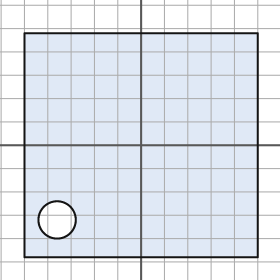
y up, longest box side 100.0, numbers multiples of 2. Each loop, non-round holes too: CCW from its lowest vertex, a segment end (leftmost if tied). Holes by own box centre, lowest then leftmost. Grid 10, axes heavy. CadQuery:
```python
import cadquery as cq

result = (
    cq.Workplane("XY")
    .moveTo(-50.0, -48.0)
    .lineTo(50.0, -48.0)
    .lineTo(50.0, 48.0)
    .lineTo(-50.0, 48.0)
    .close()
    .moveTo(-36.0, -32.0)
    .circle(8.0)
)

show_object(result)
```